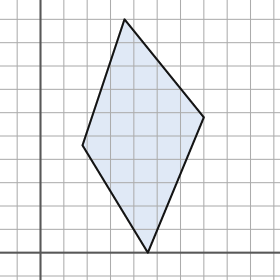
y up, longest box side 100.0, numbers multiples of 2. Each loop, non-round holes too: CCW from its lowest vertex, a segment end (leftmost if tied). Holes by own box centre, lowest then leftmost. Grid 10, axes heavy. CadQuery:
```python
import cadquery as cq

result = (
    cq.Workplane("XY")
    .moveTo(46.0, 0.0)
    .lineTo(70.0, 58.0)
    .lineTo(36.0, 100.0)
    .lineTo(18.0, 46.0)
    .close()
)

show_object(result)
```